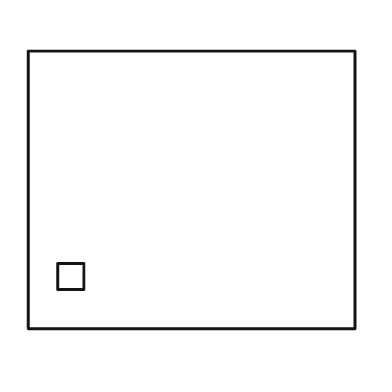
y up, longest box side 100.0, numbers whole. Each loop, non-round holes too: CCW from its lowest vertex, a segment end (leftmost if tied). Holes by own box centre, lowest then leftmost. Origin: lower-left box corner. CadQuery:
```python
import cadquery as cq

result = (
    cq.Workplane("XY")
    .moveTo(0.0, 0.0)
    .lineTo(100.0, 0.0)
    .lineTo(100.0, 85.0)
    .lineTo(0.0, 85.0)
    .close()
    .moveTo(9.0, 12.0)
    .lineTo(17.0, 12.0)
    .lineTo(17.0, 20.0)
    .lineTo(9.0, 20.0)
    .close()
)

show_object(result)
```